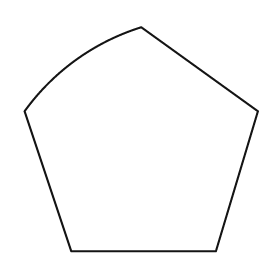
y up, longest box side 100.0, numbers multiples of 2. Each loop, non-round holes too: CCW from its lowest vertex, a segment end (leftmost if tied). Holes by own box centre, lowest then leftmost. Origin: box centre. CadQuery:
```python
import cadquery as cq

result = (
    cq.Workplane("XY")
    .moveTo(-30.0, -48.0)
    .lineTo(32.0, -48.0)
    .lineTo(50.0, 12.0)
    .lineTo(0.0, 48.0)
    .threePointArc((-28.0, 34.0), (-50.0, 12.0))
    .close()
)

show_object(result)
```